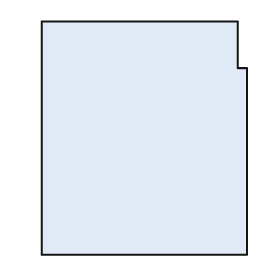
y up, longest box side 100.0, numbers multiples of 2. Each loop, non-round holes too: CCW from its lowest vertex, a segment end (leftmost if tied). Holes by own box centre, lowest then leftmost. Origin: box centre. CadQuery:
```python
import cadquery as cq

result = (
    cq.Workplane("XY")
    .moveTo(-44.0, -50.0)
    .lineTo(44.0, -50.0)
    .lineTo(44.0, 30.0)
    .lineTo(40.0, 30.0)
    .lineTo(40.0, 50.0)
    .lineTo(-44.0, 50.0)
    .close()
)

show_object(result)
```